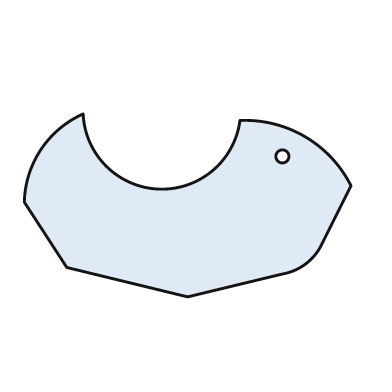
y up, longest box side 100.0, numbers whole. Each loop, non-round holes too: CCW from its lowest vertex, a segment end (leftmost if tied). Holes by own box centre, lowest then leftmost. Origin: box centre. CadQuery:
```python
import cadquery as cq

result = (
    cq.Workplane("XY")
    .moveTo(0.0, -28.0)
    .lineTo(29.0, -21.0)
    .threePointArc((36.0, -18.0), (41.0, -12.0))
    .lineTo(50.0, 6.0)
    .threePointArc((36.0, 21.0), (16.0, 26.0))
    .threePointArc((-9.0, 5.0), (-32.0, 28.0))
    .threePointArc((-45.0, 17.0), (-50.0, 1.0))
    .lineTo(-37.0, -19.0)
    .close()
    .moveTo(29.0, 15.0)
    .circle(2.0)
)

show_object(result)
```